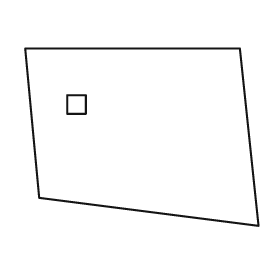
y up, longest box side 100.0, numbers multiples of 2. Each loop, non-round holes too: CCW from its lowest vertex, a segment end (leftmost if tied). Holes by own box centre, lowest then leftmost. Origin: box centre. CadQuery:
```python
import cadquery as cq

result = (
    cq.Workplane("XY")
    .moveTo(50.0, -38.0)
    .lineTo(42.0, 38.0)
    .lineTo(-50.0, 38.0)
    .lineTo(-44.0, -26.0)
    .close()
    .moveTo(-32.0, 10.0)
    .lineTo(-24.0, 10.0)
    .lineTo(-24.0, 18.0)
    .lineTo(-32.0, 18.0)
    .close()
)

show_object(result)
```